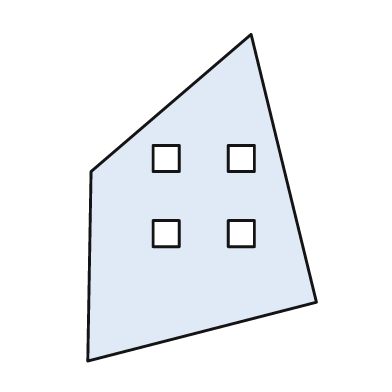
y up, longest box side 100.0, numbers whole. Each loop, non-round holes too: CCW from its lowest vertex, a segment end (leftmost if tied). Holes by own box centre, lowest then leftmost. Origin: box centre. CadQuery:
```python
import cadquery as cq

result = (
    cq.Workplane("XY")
    .moveTo(-35.0, -50.0)
    .lineTo(35.0, -32.0)
    .lineTo(15.0, 50.0)
    .lineTo(-34.0, 8.0)
    .close()
    .moveTo(-15.0, -15.0)
    .lineTo(-7.0, -15.0)
    .lineTo(-7.0, -7.0)
    .lineTo(-15.0, -7.0)
    .close()
    .moveTo(8.0, -15.0)
    .lineTo(16.0, -15.0)
    .lineTo(16.0, -7.0)
    .lineTo(8.0, -7.0)
    .close()
    .moveTo(-15.0, 8.0)
    .lineTo(-7.0, 8.0)
    .lineTo(-7.0, 16.0)
    .lineTo(-15.0, 16.0)
    .close()
    .moveTo(8.0, 8.0)
    .lineTo(16.0, 8.0)
    .lineTo(16.0, 16.0)
    .lineTo(8.0, 16.0)
    .close()
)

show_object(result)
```